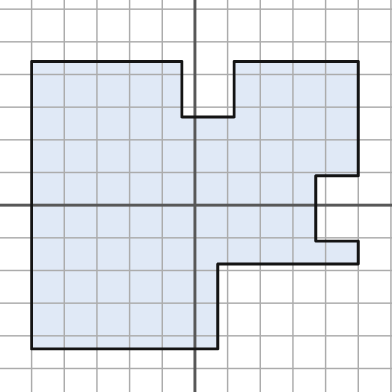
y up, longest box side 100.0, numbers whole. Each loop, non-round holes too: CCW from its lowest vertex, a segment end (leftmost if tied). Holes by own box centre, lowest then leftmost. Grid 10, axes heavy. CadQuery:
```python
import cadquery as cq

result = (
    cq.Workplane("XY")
    .moveTo(-50.0, -44.0)
    .lineTo(7.0, -44.0)
    .lineTo(7.0, -18.0)
    .lineTo(50.0, -18.0)
    .lineTo(50.0, -11.0)
    .lineTo(37.0, -11.0)
    .lineTo(37.0, 9.0)
    .lineTo(50.0, 9.0)
    .lineTo(50.0, 44.0)
    .lineTo(12.0, 44.0)
    .lineTo(12.0, 27.0)
    .lineTo(-4.0, 27.0)
    .lineTo(-4.0, 44.0)
    .lineTo(-50.0, 44.0)
    .close()
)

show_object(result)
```